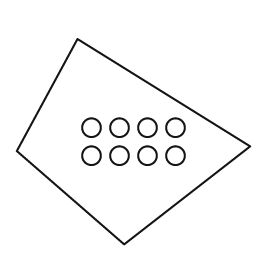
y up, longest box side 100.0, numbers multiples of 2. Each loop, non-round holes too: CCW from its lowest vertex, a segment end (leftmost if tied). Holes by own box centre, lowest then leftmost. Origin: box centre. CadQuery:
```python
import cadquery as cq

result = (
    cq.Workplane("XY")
    .moveTo(-4.0, -44.0)
    .lineTo(50.0, -2.0)
    .lineTo(-24.0, 44.0)
    .lineTo(-50.0, -4.0)
    .close()
    .moveTo(-18.0, -6.0)
    .circle(4.0)
    .moveTo(-6.0, -6.0)
    .circle(4.0)
    .moveTo(6.0, -6.0)
    .circle(4.0)
    .moveTo(18.0, -6.0)
    .circle(4.0)
    .moveTo(-18.0, 6.0)
    .circle(4.0)
    .moveTo(-6.0, 6.0)
    .circle(4.0)
    .moveTo(6.0, 6.0)
    .circle(4.0)
    .moveTo(18.0, 6.0)
    .circle(4.0)
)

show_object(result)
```